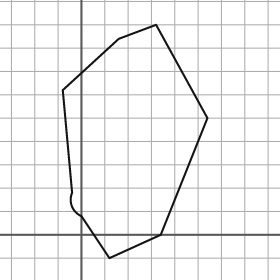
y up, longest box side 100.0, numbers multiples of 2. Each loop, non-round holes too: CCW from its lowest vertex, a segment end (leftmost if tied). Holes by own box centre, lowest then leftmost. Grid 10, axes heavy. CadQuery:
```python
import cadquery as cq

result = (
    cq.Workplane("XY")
    .moveTo(12.0, -10.0)
    .lineTo(34.0, 0.0)
    .lineTo(54.0, 50.0)
    .lineTo(32.0, 90.0)
    .lineTo(16.0, 84.0)
    .lineTo(-8.0, 62.0)
    .lineTo(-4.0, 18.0)
    .threePointArc((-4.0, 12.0), (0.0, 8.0))
    .close()
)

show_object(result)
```